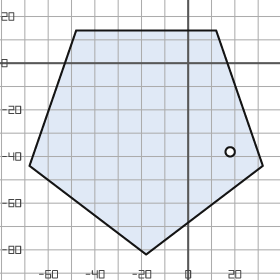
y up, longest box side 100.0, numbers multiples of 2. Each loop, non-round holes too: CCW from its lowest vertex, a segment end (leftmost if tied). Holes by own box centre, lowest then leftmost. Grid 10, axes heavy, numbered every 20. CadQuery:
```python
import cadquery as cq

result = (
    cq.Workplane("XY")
    .moveTo(-18.0, -82.0)
    .lineTo(32.0, -44.0)
    .lineTo(12.0, 14.0)
    .lineTo(-48.0, 14.0)
    .lineTo(-68.0, -44.0)
    .close()
    .moveTo(18.0, -38.0)
    .circle(2.0)
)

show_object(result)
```